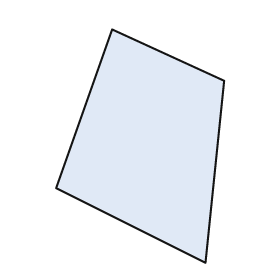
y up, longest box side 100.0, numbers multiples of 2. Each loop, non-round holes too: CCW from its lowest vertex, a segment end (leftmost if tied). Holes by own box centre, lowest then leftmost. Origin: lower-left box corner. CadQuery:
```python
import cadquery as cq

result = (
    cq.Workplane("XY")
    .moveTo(64.0, 0.0)
    .lineTo(72.0, 78.0)
    .lineTo(24.0, 100.0)
    .lineTo(0.0, 32.0)
    .close()
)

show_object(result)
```